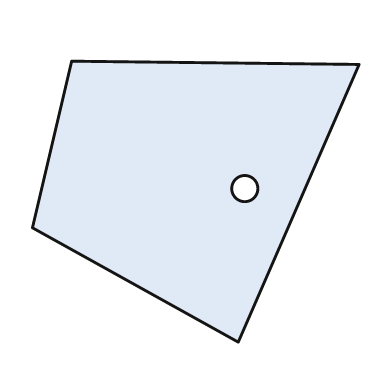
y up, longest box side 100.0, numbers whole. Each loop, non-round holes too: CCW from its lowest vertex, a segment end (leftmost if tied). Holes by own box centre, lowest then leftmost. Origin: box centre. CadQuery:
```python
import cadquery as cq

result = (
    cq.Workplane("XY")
    .moveTo(13.0, -43.0)
    .lineTo(50.0, 42.0)
    .lineTo(-38.0, 43.0)
    .lineTo(-50.0, -8.0)
    .close()
    .moveTo(15.0, 4.0)
    .circle(4.0)
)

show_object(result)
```